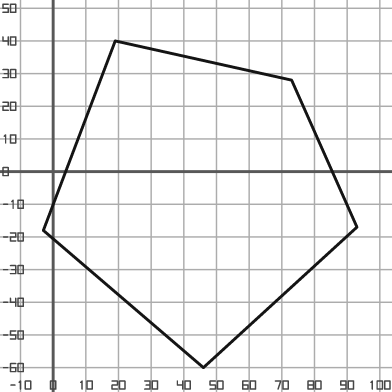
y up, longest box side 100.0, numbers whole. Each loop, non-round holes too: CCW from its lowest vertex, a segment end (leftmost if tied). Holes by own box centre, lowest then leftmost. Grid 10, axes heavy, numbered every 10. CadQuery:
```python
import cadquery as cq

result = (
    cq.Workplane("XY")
    .moveTo(46.0, -60.0)
    .lineTo(93.0, -17.0)
    .lineTo(73.0, 28.0)
    .lineTo(19.0, 40.0)
    .lineTo(-3.0, -18.0)
    .close()
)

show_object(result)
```